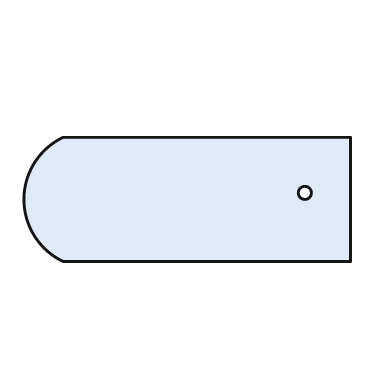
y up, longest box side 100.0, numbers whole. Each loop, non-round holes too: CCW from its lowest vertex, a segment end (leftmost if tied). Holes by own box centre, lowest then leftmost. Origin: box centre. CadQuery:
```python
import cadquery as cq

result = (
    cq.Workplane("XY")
    .moveTo(-38.0, -19.0)
    .lineTo(50.0, -19.0)
    .lineTo(50.0, 19.0)
    .lineTo(-38.0, 19.0)
    .threePointArc((-50.0, 0.0), (-38.0, -19.0))
    .close()
    .moveTo(36.0, 2.0)
    .circle(2.0)
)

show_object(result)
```